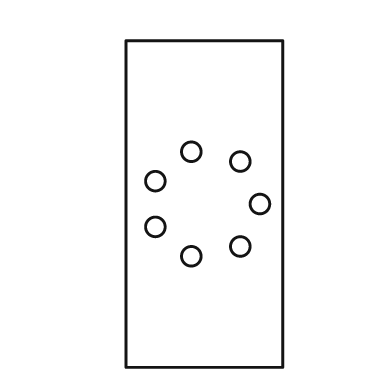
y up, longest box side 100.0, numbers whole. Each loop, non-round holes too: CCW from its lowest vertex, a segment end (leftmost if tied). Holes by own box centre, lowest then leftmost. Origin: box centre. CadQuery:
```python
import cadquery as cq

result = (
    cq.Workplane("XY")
    .moveTo(-24.0, -50.0)
    .lineTo(24.0, -50.0)
    .lineTo(24.0, 50.0)
    .lineTo(-24.0, 50.0)
    .close()
    .moveTo(-4.0, -16.0)
    .circle(3.0)
    .moveTo(11.0, -13.0)
    .circle(3.0)
    .moveTo(-15.0, -7.0)
    .circle(3.0)
    .moveTo(17.0, 0.0)
    .circle(3.0)
    .moveTo(-15.0, 7.0)
    .circle(3.0)
    .moveTo(11.0, 13.0)
    .circle(3.0)
    .moveTo(-4.0, 16.0)
    .circle(3.0)
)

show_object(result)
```